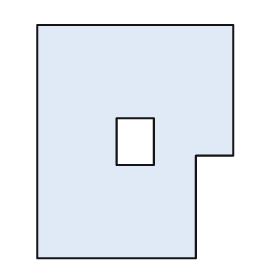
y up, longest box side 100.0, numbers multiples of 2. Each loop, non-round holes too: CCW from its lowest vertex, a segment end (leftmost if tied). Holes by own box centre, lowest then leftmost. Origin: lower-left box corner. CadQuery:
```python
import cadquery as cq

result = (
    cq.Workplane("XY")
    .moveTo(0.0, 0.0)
    .lineTo(68.0, 0.0)
    .lineTo(68.0, 44.0)
    .lineTo(84.0, 44.0)
    .lineTo(84.0, 100.0)
    .lineTo(0.0, 100.0)
    .close()
    .moveTo(34.0, 40.0)
    .lineTo(50.0, 40.0)
    .lineTo(50.0, 60.0)
    .lineTo(34.0, 60.0)
    .close()
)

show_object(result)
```